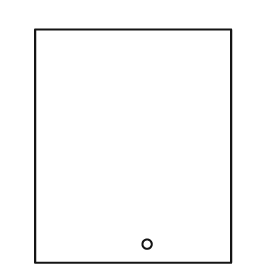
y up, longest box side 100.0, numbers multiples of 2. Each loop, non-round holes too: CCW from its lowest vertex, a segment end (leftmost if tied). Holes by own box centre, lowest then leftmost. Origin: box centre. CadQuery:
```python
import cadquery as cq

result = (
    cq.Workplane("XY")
    .moveTo(-42.0, -50.0)
    .lineTo(42.0, -50.0)
    .lineTo(42.0, 50.0)
    .lineTo(-42.0, 50.0)
    .close()
    .moveTo(6.0, -42.0)
    .circle(2.0)
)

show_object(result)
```